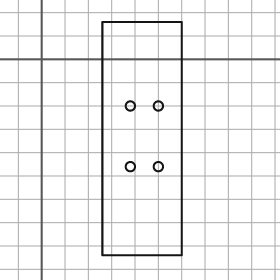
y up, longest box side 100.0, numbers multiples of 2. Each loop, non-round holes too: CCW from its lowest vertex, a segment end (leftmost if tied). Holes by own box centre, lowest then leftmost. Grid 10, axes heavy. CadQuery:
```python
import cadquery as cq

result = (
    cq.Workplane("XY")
    .moveTo(26.0, -84.0)
    .lineTo(60.0, -84.0)
    .lineTo(60.0, 16.0)
    .lineTo(26.0, 16.0)
    .close()
    .moveTo(38.0, -46.0)
    .circle(2.0)
    .moveTo(50.0, -46.0)
    .circle(2.0)
    .moveTo(38.0, -20.0)
    .circle(2.0)
    .moveTo(50.0, -20.0)
    .circle(2.0)
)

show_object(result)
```